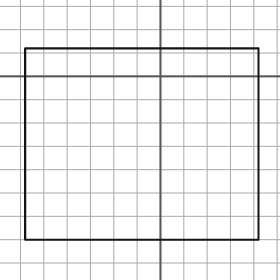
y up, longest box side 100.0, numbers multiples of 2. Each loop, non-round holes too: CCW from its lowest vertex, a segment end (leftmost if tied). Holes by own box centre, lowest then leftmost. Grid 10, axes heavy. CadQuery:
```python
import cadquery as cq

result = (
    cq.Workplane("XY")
    .moveTo(-58.0, -70.0)
    .lineTo(42.0, -70.0)
    .lineTo(42.0, 12.0)
    .lineTo(-58.0, 12.0)
    .close()
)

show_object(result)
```